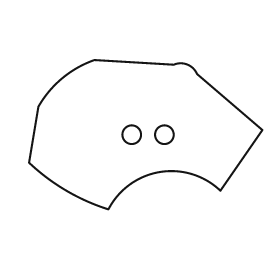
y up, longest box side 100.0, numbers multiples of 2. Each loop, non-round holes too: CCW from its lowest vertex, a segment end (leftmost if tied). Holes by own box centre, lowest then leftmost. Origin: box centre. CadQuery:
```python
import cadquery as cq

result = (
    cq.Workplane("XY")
    .moveTo(-16.0, -32.0)
    .threePointArc((6.0, -16.0), (32.0, -24.0))
    .lineTo(50.0, 2.0)
    .lineTo(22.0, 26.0)
    .threePointArc((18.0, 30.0), (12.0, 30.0))
    .lineTo(-22.0, 32.0)
    .threePointArc((-36.0, 24.0), (-46.0, 12.0))
    .lineTo(-50.0, -12.0)
    .threePointArc((-34.0, -24.0), (-16.0, -32.0))
    .close()
    .moveTo(-6.0, 0.0)
    .circle(4.0)
    .moveTo(8.0, 0.0)
    .circle(4.0)
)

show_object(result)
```